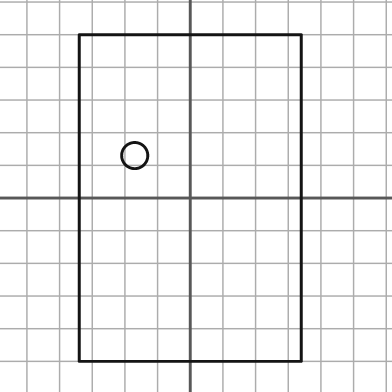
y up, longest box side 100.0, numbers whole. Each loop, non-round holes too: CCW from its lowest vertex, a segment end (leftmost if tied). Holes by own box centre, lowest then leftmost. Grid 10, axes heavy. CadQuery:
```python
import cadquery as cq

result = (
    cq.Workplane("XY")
    .moveTo(-34.0, -50.0)
    .lineTo(34.0, -50.0)
    .lineTo(34.0, 50.0)
    .lineTo(-34.0, 50.0)
    .close()
    .moveTo(-17.0, 13.0)
    .circle(4.0)
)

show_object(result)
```